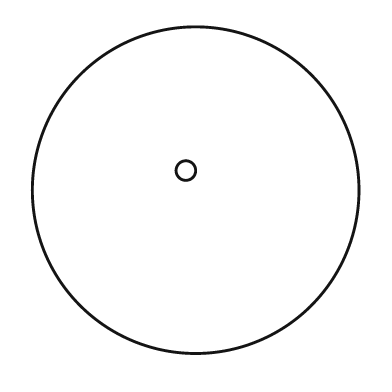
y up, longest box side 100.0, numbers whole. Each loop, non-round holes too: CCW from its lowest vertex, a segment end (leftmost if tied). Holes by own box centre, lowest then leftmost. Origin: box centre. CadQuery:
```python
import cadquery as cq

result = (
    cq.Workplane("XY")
    .moveTo(0.0, 0.0)
    .circle(50.0)
    .moveTo(-3.0, 6.0)
    .circle(3.0)
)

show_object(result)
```